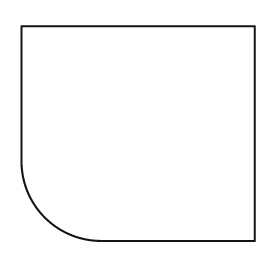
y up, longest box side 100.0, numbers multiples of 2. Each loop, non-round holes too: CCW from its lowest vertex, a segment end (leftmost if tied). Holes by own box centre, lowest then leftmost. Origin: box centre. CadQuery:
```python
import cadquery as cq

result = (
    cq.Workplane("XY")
    .moveTo(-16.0, -46.0)
    .lineTo(50.0, -46.0)
    .lineTo(50.0, 46.0)
    .lineTo(-50.0, 46.0)
    .lineTo(-50.0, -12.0)
    .threePointArc((-40.0, -36.0), (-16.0, -46.0))
    .close()
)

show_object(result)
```